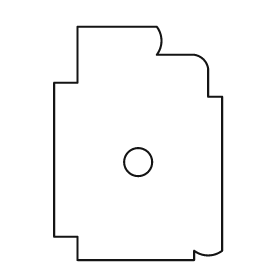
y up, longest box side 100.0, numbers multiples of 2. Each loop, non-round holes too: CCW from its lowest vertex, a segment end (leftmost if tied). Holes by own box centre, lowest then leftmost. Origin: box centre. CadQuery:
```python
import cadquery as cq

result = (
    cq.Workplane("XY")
    .moveTo(-26.0, -50.0)
    .lineTo(24.0, -50.0)
    .lineTo(24.0, -46.0)
    .threePointArc((30.0, -48.0), (36.0, -46.0))
    .lineTo(36.0, 20.0)
    .lineTo(30.0, 20.0)
    .lineTo(30.0, 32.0)
    .threePointArc((28.0, 36.0), (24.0, 38.0))
    .lineTo(8.0, 38.0)
    .threePointArc((10.0, 44.0), (8.0, 50.0))
    .lineTo(-26.0, 50.0)
    .lineTo(-26.0, 26.0)
    .lineTo(-36.0, 26.0)
    .lineTo(-36.0, -40.0)
    .lineTo(-26.0, -40.0)
    .close()
    .moveTo(0.0, -8.0)
    .circle(6.0)
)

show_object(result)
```